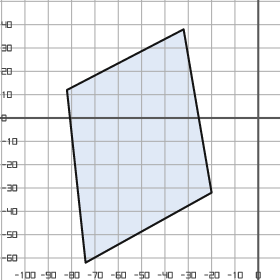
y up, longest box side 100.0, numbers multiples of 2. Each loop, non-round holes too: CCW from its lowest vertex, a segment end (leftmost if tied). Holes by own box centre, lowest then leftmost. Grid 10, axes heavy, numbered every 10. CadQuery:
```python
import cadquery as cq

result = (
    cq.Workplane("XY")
    .moveTo(-74.0, -62.0)
    .lineTo(-20.0, -32.0)
    .lineTo(-32.0, 38.0)
    .lineTo(-82.0, 12.0)
    .close()
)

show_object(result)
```